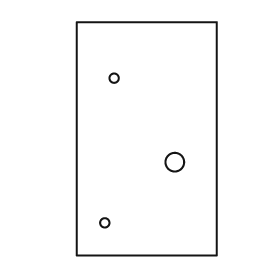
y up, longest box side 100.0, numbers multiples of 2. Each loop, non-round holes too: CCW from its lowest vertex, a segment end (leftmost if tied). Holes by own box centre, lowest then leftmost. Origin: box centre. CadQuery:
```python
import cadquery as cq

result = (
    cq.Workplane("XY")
    .moveTo(-30.0, -50.0)
    .lineTo(30.0, -50.0)
    .lineTo(30.0, 50.0)
    .lineTo(-30.0, 50.0)
    .close()
    .moveTo(-18.0, -36.0)
    .circle(2.0)
    .moveTo(12.0, -10.0)
    .circle(4.0)
    .moveTo(-14.0, 26.0)
    .circle(2.0)
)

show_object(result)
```